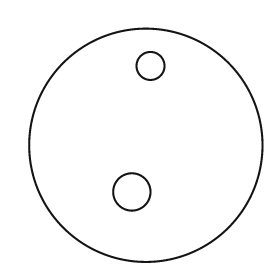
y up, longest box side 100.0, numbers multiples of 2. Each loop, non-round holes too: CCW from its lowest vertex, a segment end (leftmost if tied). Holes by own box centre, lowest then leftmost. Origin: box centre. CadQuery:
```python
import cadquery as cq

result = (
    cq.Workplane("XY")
    .moveTo(0.0, 0.0)
    .circle(50.0)
    .moveTo(-6.0, -20.0)
    .circle(8.0)
    .moveTo(2.0, 34.0)
    .circle(6.0)
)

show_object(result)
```